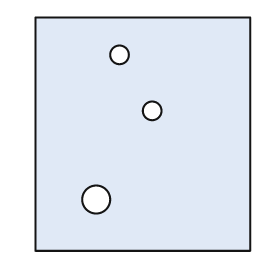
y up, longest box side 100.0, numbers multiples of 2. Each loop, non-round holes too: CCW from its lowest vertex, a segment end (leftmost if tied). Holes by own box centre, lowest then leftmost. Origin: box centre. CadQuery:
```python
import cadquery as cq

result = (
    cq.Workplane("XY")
    .moveTo(-46.0, -50.0)
    .lineTo(46.0, -50.0)
    .lineTo(46.0, 50.0)
    .lineTo(-46.0, 50.0)
    .close()
    .moveTo(-20.0, -28.0)
    .circle(6.0)
    .moveTo(4.0, 10.0)
    .circle(4.0)
    .moveTo(-10.0, 34.0)
    .circle(4.0)
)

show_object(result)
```